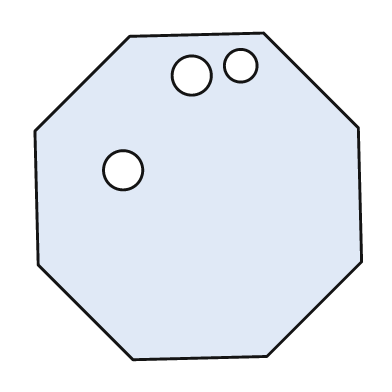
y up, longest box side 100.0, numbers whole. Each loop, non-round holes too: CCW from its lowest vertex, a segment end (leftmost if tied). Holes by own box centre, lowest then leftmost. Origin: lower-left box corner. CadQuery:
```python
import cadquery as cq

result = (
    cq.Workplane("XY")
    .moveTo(30.0, 0.0)
    .lineTo(71.0, 1.0)
    .lineTo(100.0, 30.0)
    .lineTo(99.0, 71.0)
    .lineTo(70.0, 100.0)
    .lineTo(29.0, 99.0)
    .lineTo(0.0, 70.0)
    .lineTo(1.0, 29.0)
    .close()
    .moveTo(27.0, 58.0)
    .circle(6.0)
    .moveTo(48.0, 87.0)
    .circle(6.0)
    .moveTo(63.0, 90.0)
    .circle(5.0)
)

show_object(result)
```